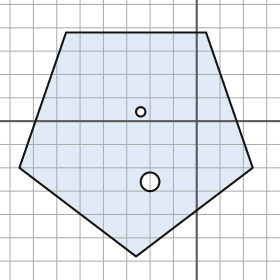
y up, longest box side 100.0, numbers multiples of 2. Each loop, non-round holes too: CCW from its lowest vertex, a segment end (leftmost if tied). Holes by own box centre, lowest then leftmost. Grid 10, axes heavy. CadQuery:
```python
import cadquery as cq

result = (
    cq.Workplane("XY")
    .moveTo(-26.0, -58.0)
    .lineTo(24.0, -20.0)
    .lineTo(4.0, 38.0)
    .lineTo(-56.0, 38.0)
    .lineTo(-76.0, -20.0)
    .close()
    .moveTo(-20.0, -26.0)
    .circle(4.0)
    .moveTo(-24.0, 4.0)
    .circle(2.0)
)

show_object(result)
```